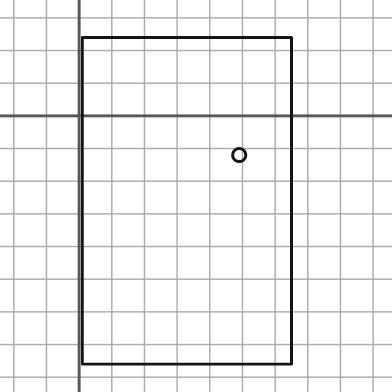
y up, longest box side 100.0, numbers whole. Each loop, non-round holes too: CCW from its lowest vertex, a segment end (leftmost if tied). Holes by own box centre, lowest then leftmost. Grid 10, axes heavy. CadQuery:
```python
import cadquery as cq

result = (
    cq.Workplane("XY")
    .moveTo(1.0, -76.0)
    .lineTo(65.0, -76.0)
    .lineTo(65.0, 24.0)
    .lineTo(1.0, 24.0)
    .close()
    .moveTo(49.0, -12.0)
    .circle(2.0)
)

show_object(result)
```